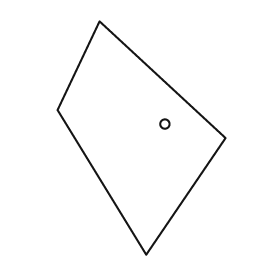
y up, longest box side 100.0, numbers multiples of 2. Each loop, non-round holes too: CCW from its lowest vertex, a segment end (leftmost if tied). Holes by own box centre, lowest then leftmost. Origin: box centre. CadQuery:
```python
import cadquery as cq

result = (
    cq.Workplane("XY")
    .moveTo(2.0, -50.0)
    .lineTo(36.0, 0.0)
    .lineTo(-18.0, 50.0)
    .lineTo(-36.0, 12.0)
    .close()
    .moveTo(10.0, 6.0)
    .circle(2.0)
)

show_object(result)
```